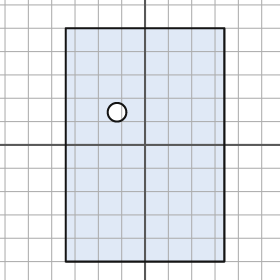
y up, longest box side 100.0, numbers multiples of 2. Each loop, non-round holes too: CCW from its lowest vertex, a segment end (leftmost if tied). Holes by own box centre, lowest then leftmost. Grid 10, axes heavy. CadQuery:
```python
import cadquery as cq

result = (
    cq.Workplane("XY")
    .moveTo(-34.0, -50.0)
    .lineTo(34.0, -50.0)
    .lineTo(34.0, 50.0)
    .lineTo(-34.0, 50.0)
    .close()
    .moveTo(-12.0, 14.0)
    .circle(4.0)
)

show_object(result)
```